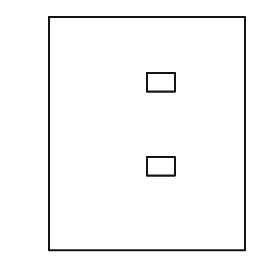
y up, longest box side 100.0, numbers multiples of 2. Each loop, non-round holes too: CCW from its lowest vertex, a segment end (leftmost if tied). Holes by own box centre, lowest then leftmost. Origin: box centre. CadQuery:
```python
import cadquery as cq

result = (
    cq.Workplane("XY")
    .moveTo(-42.0, -50.0)
    .lineTo(42.0, -50.0)
    .lineTo(42.0, 50.0)
    .lineTo(-42.0, 50.0)
    .close()
    .moveTo(0.0, -18.0)
    .lineTo(12.0, -18.0)
    .lineTo(12.0, -10.0)
    .lineTo(0.0, -10.0)
    .close()
    .moveTo(0.0, 18.0)
    .lineTo(12.0, 18.0)
    .lineTo(12.0, 26.0)
    .lineTo(0.0, 26.0)
    .close()
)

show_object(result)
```